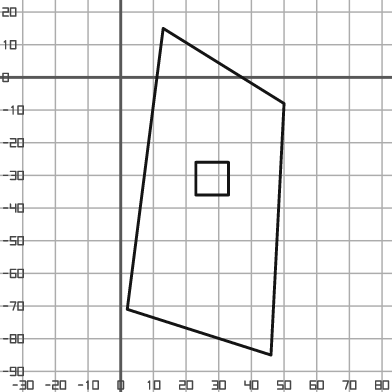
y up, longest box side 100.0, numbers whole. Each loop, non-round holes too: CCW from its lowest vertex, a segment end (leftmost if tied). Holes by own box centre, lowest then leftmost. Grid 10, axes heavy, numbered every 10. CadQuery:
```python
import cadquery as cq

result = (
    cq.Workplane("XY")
    .moveTo(46.0, -85.0)
    .lineTo(50.0, -8.0)
    .lineTo(13.0, 15.0)
    .lineTo(2.0, -71.0)
    .close()
    .moveTo(23.0, -36.0)
    .lineTo(33.0, -36.0)
    .lineTo(33.0, -26.0)
    .lineTo(23.0, -26.0)
    .close()
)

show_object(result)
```